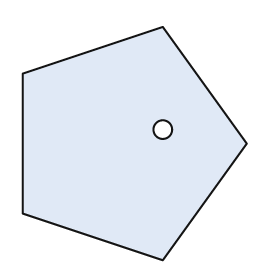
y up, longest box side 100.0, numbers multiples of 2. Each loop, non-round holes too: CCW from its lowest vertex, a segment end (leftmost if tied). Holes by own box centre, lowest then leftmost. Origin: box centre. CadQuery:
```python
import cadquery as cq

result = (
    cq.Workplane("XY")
    .moveTo(12.0, -50.0)
    .lineTo(48.0, 0.0)
    .lineTo(12.0, 50.0)
    .lineTo(-48.0, 30.0)
    .lineTo(-48.0, -30.0)
    .close()
    .moveTo(12.0, 6.0)
    .circle(4.0)
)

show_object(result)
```